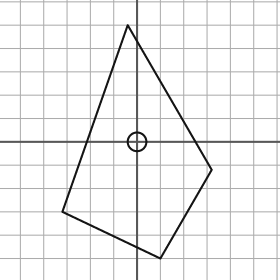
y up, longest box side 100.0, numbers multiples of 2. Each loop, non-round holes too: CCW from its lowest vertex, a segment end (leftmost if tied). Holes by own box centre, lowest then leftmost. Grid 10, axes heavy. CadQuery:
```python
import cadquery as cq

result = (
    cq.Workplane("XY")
    .moveTo(10.0, -50.0)
    .lineTo(32.0, -12.0)
    .lineTo(-4.0, 50.0)
    .lineTo(-32.0, -30.0)
    .close()
    .moveTo(0.0, 0.0)
    .circle(4.0)
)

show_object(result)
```